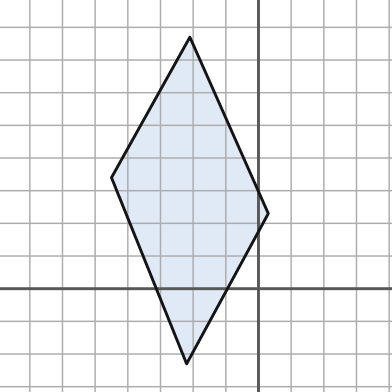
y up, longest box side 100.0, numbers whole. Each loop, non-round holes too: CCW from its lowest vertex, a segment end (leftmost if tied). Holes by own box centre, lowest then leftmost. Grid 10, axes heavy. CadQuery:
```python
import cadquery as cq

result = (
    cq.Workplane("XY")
    .moveTo(-22.0, -23.0)
    .lineTo(3.0, 23.0)
    .lineTo(-21.0, 77.0)
    .lineTo(-45.0, 34.0)
    .close()
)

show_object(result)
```